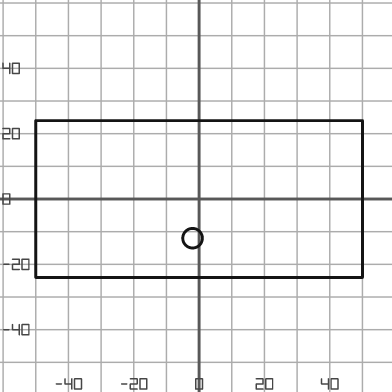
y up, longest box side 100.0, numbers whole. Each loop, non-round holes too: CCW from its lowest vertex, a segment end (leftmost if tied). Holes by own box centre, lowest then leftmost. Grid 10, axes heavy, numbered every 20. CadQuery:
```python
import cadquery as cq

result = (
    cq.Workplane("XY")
    .moveTo(-50.0, -24.0)
    .lineTo(50.0, -24.0)
    .lineTo(50.0, 24.0)
    .lineTo(-50.0, 24.0)
    .close()
    .moveTo(-2.0, -12.0)
    .circle(3.0)
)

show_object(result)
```